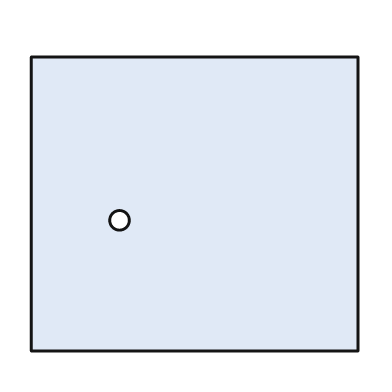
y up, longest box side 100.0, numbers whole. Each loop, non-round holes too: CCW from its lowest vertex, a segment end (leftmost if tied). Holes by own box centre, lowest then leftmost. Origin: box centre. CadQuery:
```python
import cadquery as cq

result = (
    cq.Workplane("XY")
    .moveTo(-50.0, -45.0)
    .lineTo(50.0, -45.0)
    .lineTo(50.0, 45.0)
    .lineTo(-50.0, 45.0)
    .close()
    .moveTo(-23.0, -5.0)
    .circle(3.0)
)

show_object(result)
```